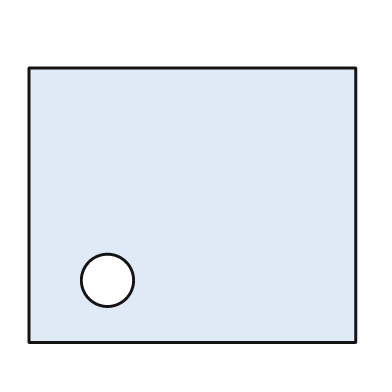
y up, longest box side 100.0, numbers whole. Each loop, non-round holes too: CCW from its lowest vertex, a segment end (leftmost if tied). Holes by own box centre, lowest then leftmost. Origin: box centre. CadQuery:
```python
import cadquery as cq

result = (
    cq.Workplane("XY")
    .moveTo(-50.0, -42.0)
    .lineTo(50.0, -42.0)
    .lineTo(50.0, 42.0)
    .lineTo(-50.0, 42.0)
    .close()
    .moveTo(-26.0, -23.0)
    .circle(8.0)
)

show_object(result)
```